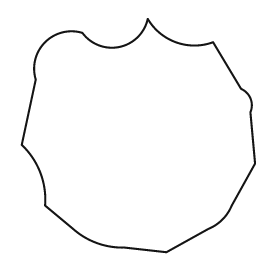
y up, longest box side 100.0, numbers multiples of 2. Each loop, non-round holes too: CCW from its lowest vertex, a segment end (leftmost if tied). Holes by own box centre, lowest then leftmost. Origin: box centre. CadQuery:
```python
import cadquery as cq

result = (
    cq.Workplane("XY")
    .moveTo(12.0, -50.0)
    .lineTo(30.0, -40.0)
    .threePointArc((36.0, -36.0), (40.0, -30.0))
    .lineTo(50.0, -12.0)
    .lineTo(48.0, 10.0)
    .threePointArc((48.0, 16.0), (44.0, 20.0))
    .lineTo(32.0, 40.0)
    .threePointArc((16.0, 40.0), (4.0, 50.0))
    .threePointArc((-8.0, 38.0), (-24.0, 44.0))
    .threePointArc((-40.0, 40.0), (-44.0, 24.0))
    .lineTo(-50.0, -4.0)
    .threePointArc((-42.0, -16.0), (-40.0, -30.0))
    .lineTo(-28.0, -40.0)
    .threePointArc((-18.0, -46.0), (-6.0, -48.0))
    .close()
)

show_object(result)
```